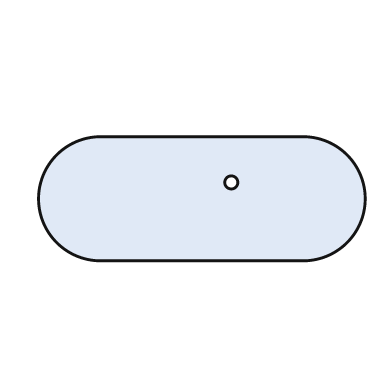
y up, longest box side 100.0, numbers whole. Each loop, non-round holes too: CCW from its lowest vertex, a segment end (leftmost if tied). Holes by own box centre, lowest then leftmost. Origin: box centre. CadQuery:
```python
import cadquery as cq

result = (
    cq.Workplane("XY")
    .moveTo(-31.0, -19.0)
    .lineTo(31.0, -19.0)
    .threePointArc((50.0, 0.0), (31.0, 19.0))
    .lineTo(-31.0, 19.0)
    .threePointArc((-50.0, 0.0), (-31.0, -19.0))
    .close()
    .moveTo(9.0, 5.0)
    .circle(2.0)
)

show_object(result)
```